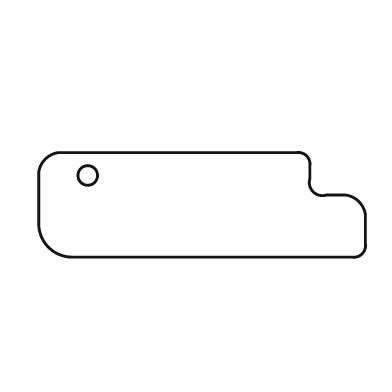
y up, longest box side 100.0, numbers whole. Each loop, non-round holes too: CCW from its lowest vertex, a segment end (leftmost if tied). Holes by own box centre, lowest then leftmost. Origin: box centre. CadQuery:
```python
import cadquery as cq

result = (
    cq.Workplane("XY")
    .moveTo(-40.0, -16.0)
    .lineTo(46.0, -16.0)
    .threePointArc((49.0, -15.0), (50.0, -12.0))
    .lineTo(50.0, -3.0)
    .threePointArc((48.0, 1.0), (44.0, 3.0))
    .lineTo(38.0, 3.0)
    .threePointArc((34.0, 4.0), (33.0, 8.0))
    .lineTo(33.0, 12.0)
    .threePointArc((32.0, 15.0), (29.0, 16.0))
    .lineTo(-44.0, 16.0)
    .threePointArc((-48.0, 14.0), (-50.0, 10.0))
    .lineTo(-50.0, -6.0)
    .threePointArc((-47.0, -13.0), (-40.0, -16.0))
    .close()
    .moveTo(-35.0, 9.0)
    .circle(3.0)
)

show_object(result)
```